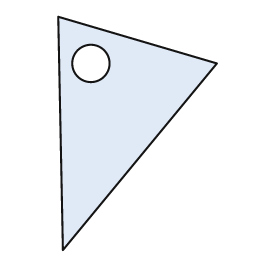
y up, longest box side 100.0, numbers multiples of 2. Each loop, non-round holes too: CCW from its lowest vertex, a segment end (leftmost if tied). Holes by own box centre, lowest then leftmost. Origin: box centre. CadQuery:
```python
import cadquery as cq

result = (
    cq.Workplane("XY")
    .moveTo(-32.0, -50.0)
    .lineTo(34.0, 30.0)
    .lineTo(-34.0, 50.0)
    .close()
    .moveTo(-20.0, 30.0)
    .circle(8.0)
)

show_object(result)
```